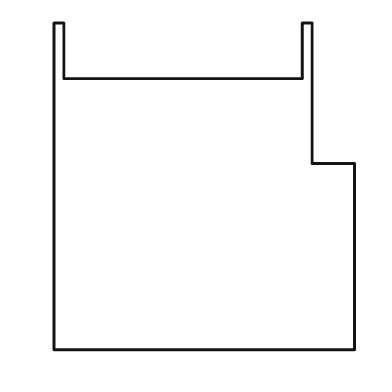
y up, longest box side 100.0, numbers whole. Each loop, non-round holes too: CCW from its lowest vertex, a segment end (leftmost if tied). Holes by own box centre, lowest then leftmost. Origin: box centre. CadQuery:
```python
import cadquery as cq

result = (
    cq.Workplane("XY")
    .moveTo(-46.0, -50.0)
    .lineTo(46.0, -50.0)
    .lineTo(46.0, 7.0)
    .lineTo(33.0, 7.0)
    .lineTo(33.0, 50.0)
    .lineTo(30.0, 50.0)
    .lineTo(30.0, 33.0)
    .lineTo(-43.0, 33.0)
    .lineTo(-43.0, 50.0)
    .lineTo(-46.0, 50.0)
    .close()
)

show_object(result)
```